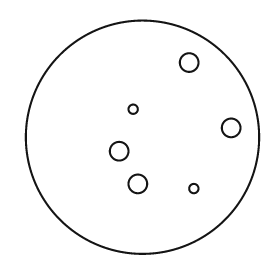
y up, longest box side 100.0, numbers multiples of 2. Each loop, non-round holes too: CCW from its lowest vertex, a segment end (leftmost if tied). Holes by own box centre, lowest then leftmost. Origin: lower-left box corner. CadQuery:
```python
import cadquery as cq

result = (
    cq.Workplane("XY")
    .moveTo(50.0, 50.0)
    .circle(50.0)
    .moveTo(72.0, 28.0)
    .circle(2.0)
    .moveTo(48.0, 30.0)
    .circle(4.0)
    .moveTo(40.0, 44.0)
    .circle(4.0)
    .moveTo(88.0, 54.0)
    .circle(4.0)
    .moveTo(46.0, 62.0)
    .circle(2.0)
    .moveTo(70.0, 82.0)
    .circle(4.0)
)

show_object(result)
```